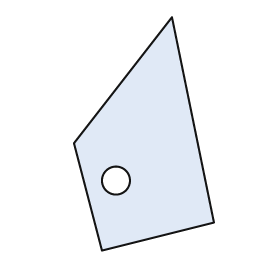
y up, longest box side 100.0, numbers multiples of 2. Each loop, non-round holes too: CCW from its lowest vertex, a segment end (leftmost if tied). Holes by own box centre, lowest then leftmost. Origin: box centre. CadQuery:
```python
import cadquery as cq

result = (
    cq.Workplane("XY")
    .moveTo(-18.0, -50.0)
    .lineTo(30.0, -38.0)
    .lineTo(12.0, 50.0)
    .lineTo(-30.0, -4.0)
    .close()
    .moveTo(-12.0, -20.0)
    .circle(6.0)
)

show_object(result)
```